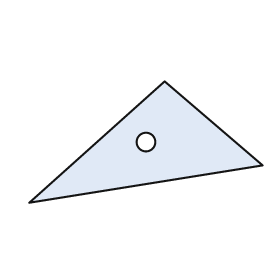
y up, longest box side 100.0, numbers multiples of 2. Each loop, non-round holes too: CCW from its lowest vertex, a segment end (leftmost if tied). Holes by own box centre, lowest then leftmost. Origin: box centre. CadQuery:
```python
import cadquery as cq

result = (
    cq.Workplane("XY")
    .moveTo(-50.0, -26.0)
    .lineTo(50.0, -10.0)
    .lineTo(8.0, 26.0)
    .close()
    .moveTo(0.0, 0.0)
    .circle(4.0)
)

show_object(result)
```